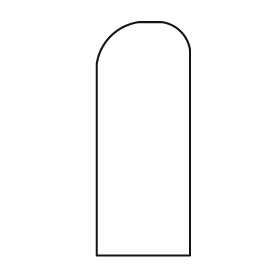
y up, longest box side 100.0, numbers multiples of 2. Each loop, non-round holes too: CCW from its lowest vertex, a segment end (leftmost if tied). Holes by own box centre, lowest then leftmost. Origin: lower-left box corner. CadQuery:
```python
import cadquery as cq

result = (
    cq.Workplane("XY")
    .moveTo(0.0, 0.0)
    .lineTo(40.0, 0.0)
    .lineTo(40.0, 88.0)
    .threePointArc((36.0, 96.0), (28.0, 100.0))
    .lineTo(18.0, 100.0)
    .threePointArc((6.0, 94.0), (0.0, 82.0))
    .close()
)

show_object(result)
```